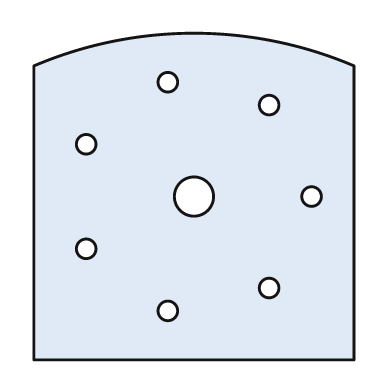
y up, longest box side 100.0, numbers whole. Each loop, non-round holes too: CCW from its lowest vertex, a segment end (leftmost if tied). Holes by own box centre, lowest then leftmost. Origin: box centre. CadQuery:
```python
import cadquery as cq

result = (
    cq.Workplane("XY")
    .moveTo(-49.0, -50.0)
    .lineTo(49.0, -50.0)
    .lineTo(49.0, 40.0)
    .threePointArc((0.0, 50.0), (-49.0, 40.0))
    .close()
    .moveTo(-8.0, -35.0)
    .circle(3.0)
    .moveTo(23.0, -28.0)
    .circle(3.0)
    .moveTo(-33.0, -16.0)
    .circle(3.0)
    .moveTo(0.0, 0.0)
    .circle(6.0)
    .moveTo(36.0, 0.0)
    .circle(3.0)
    .moveTo(-33.0, 16.0)
    .circle(3.0)
    .moveTo(23.0, 28.0)
    .circle(3.0)
    .moveTo(-8.0, 35.0)
    .circle(3.0)
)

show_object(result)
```